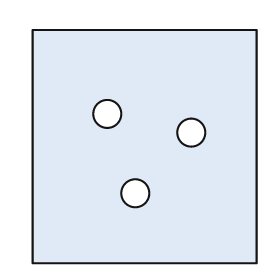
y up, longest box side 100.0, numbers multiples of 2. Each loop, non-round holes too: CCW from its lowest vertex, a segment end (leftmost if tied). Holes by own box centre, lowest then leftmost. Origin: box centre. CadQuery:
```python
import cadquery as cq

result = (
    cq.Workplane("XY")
    .moveTo(-48.0, -50.0)
    .lineTo(48.0, -50.0)
    .lineTo(48.0, 50.0)
    .lineTo(-48.0, 50.0)
    .close()
    .moveTo(-4.0, -20.0)
    .circle(6.0)
    .moveTo(20.0, 6.0)
    .circle(6.0)
    .moveTo(-16.0, 14.0)
    .circle(6.0)
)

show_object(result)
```